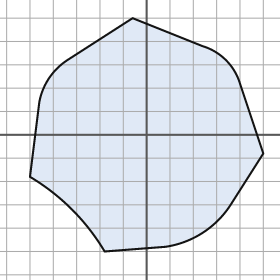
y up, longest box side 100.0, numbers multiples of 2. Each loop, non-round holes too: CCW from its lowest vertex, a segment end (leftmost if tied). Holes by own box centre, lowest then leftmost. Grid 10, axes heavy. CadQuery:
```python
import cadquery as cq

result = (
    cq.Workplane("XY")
    .moveTo(-18.0, -50.0)
    .lineTo(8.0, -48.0)
    .threePointArc((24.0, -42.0), (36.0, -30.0))
    .lineTo(50.0, -8.0)
    .lineTo(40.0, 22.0)
    .threePointArc((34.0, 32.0), (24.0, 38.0))
    .lineTo(-6.0, 50.0)
    .lineTo(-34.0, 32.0)
    .threePointArc((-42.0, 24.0), (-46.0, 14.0))
    .lineTo(-50.0, -18.0)
    .threePointArc((-32.0, -32.0), (-18.0, -50.0))
    .close()
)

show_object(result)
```